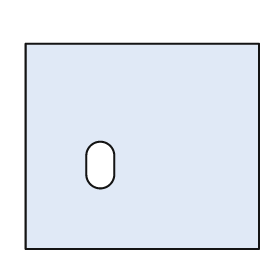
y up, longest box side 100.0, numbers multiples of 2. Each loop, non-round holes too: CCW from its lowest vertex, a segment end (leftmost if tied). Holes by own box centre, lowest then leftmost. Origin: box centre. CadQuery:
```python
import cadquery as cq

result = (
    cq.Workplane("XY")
    .moveTo(-50.0, -44.0)
    .lineTo(50.0, -44.0)
    .lineTo(50.0, 44.0)
    .lineTo(-50.0, 44.0)
    .close()
    .moveTo(-24.0, -12.0)
    .threePointArc((-18.0, -18.0), (-12.0, -12.0))
    .lineTo(-12.0, -4.0)
    .threePointArc((-18.0, 2.0), (-24.0, -4.0))
    .close()
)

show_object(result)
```